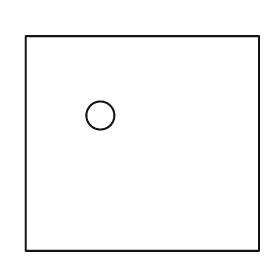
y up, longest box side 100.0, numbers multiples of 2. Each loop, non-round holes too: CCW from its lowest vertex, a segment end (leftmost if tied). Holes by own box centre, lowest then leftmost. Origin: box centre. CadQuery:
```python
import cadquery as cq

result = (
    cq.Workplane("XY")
    .moveTo(-50.0, -46.0)
    .lineTo(50.0, -46.0)
    .lineTo(50.0, 46.0)
    .lineTo(-50.0, 46.0)
    .close()
    .moveTo(-18.0, 12.0)
    .circle(6.0)
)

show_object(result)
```